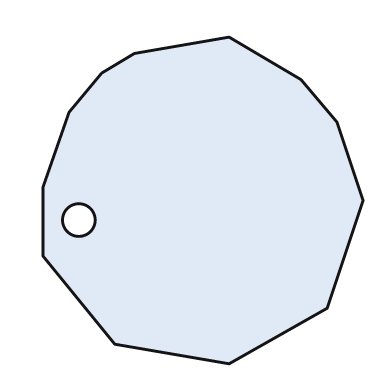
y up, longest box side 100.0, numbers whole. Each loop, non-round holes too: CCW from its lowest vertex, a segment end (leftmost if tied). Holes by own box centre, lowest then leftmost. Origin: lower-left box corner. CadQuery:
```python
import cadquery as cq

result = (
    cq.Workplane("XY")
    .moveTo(57.0, 0.0)
    .lineTo(87.0, 17.0)
    .lineTo(98.0, 50.0)
    .lineTo(90.0, 74.0)
    .lineTo(79.0, 87.0)
    .lineTo(57.0, 100.0)
    .lineTo(28.0, 95.0)
    .lineTo(18.0, 89.0)
    .lineTo(8.0, 77.0)
    .lineTo(0.0, 54.0)
    .lineTo(0.0, 33.0)
    .lineTo(22.0, 6.0)
    .close()
    .moveTo(11.0, 44.0)
    .circle(5.0)
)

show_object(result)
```